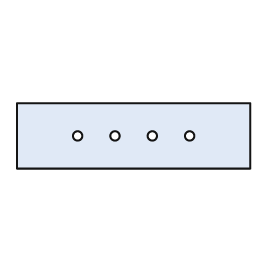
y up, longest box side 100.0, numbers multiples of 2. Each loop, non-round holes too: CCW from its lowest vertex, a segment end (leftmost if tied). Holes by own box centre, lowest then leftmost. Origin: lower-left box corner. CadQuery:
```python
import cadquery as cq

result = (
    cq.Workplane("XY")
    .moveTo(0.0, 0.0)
    .lineTo(100.0, 0.0)
    .lineTo(100.0, 28.0)
    .lineTo(0.0, 28.0)
    .close()
    .moveTo(26.0, 14.0)
    .circle(2.0)
    .moveTo(42.0, 14.0)
    .circle(2.0)
    .moveTo(58.0, 14.0)
    .circle(2.0)
    .moveTo(74.0, 14.0)
    .circle(2.0)
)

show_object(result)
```